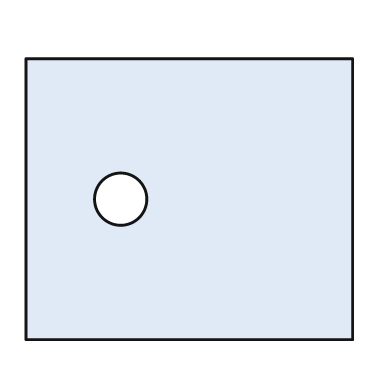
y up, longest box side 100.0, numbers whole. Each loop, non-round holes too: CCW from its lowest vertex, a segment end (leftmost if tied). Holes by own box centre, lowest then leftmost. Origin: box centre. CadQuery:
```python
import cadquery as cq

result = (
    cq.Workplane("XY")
    .moveTo(-50.0, -43.0)
    .lineTo(50.0, -43.0)
    .lineTo(50.0, 43.0)
    .lineTo(-50.0, 43.0)
    .close()
    .moveTo(-21.0, 0.0)
    .circle(8.0)
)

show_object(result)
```